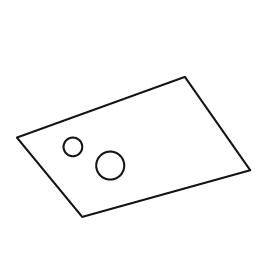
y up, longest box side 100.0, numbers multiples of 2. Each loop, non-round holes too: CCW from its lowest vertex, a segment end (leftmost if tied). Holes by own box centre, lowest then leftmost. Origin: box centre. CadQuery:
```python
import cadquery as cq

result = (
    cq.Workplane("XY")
    .moveTo(-22.0, -30.0)
    .lineTo(50.0, -10.0)
    .lineTo(22.0, 30.0)
    .lineTo(-50.0, 4.0)
    .close()
    .moveTo(-10.0, -8.0)
    .circle(6.0)
    .moveTo(-26.0, 0.0)
    .circle(4.0)
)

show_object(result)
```